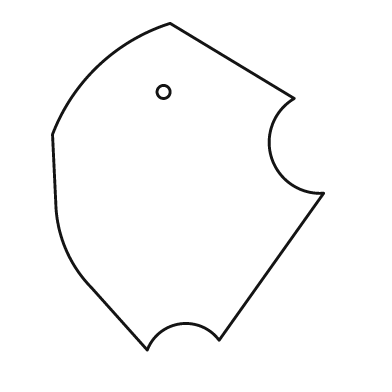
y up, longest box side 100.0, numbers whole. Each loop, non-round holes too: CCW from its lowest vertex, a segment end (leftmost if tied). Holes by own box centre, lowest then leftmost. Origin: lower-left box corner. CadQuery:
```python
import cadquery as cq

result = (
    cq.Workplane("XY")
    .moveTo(29.0, 0.0)
    .threePointArc((39.0, 8.0), (51.0, 3.0))
    .lineTo(83.0, 48.0)
    .threePointArc((67.0, 59.0), (74.0, 77.0))
    .lineTo(36.0, 100.0)
    .threePointArc((14.0, 87.0), (0.0, 66.0))
    .lineTo(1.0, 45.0)
    .threePointArc((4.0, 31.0), (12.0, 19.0))
    .close()
    .moveTo(34.0, 79.0)
    .circle(2.0)
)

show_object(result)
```